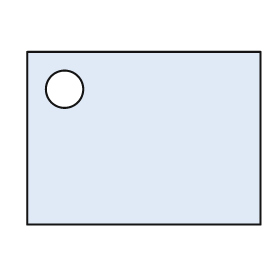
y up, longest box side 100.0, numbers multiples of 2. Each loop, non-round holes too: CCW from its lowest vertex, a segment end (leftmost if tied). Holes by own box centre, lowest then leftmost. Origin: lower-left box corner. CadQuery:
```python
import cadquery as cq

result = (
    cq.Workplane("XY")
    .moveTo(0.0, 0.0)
    .lineTo(100.0, 0.0)
    .lineTo(100.0, 74.0)
    .lineTo(0.0, 74.0)
    .close()
    .moveTo(16.0, 58.0)
    .circle(8.0)
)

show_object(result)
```